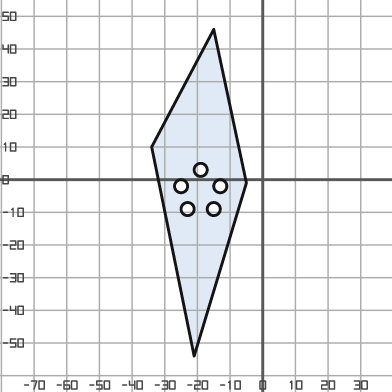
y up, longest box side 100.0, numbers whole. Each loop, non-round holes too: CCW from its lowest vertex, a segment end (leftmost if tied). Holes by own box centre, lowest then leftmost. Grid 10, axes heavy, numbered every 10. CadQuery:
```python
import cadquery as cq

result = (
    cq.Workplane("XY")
    .moveTo(-21.0, -54.0)
    .lineTo(-5.0, -1.0)
    .lineTo(-15.0, 46.0)
    .lineTo(-34.0, 10.0)
    .close()
    .moveTo(-23.0, -9.0)
    .circle(2.0)
    .moveTo(-15.0, -9.0)
    .circle(2.0)
    .moveTo(-25.0, -2.0)
    .circle(2.0)
    .moveTo(-13.0, -2.0)
    .circle(2.0)
    .moveTo(-19.0, 3.0)
    .circle(2.0)
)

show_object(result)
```